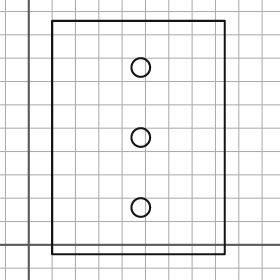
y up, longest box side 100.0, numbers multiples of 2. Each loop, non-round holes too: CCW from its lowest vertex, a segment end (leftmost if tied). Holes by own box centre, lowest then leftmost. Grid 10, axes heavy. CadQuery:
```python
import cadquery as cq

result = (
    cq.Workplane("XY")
    .moveTo(10.0, -4.0)
    .lineTo(84.0, -4.0)
    .lineTo(84.0, 96.0)
    .lineTo(10.0, 96.0)
    .close()
    .moveTo(48.0, 16.0)
    .circle(4.0)
    .moveTo(48.0, 46.0)
    .circle(4.0)
    .moveTo(48.0, 76.0)
    .circle(4.0)
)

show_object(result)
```